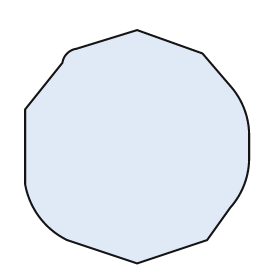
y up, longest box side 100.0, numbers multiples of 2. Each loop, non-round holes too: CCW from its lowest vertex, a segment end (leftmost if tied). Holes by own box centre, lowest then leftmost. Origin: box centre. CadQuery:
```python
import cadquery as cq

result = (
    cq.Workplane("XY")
    .moveTo(0.0, -50.0)
    .lineTo(30.0, -40.0)
    .lineTo(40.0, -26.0)
    .threePointArc((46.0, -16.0), (48.0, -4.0))
    .lineTo(48.0, 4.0)
    .threePointArc((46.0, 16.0), (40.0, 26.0))
    .lineTo(28.0, 40.0)
    .lineTo(0.0, 50.0)
    .lineTo(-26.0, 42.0)
    .threePointArc((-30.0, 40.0), (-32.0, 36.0))
    .lineTo(-48.0, 16.0)
    .lineTo(-48.0, -16.0)
    .threePointArc((-42.0, -30.0), (-30.0, -40.0))
    .close()
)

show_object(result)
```